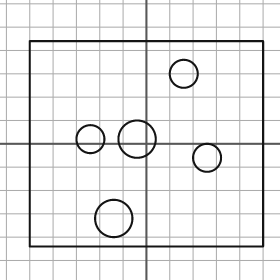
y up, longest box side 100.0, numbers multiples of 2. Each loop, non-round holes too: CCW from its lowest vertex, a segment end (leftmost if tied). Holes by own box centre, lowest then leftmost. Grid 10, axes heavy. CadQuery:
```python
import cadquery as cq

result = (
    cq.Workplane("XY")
    .moveTo(-50.0, -44.0)
    .lineTo(50.0, -44.0)
    .lineTo(50.0, 44.0)
    .lineTo(-50.0, 44.0)
    .close()
    .moveTo(-14.0, -32.0)
    .circle(8.0)
    .moveTo(26.0, -6.0)
    .circle(6.0)
    .moveTo(-24.0, 2.0)
    .circle(6.0)
    .moveTo(-4.0, 2.0)
    .circle(8.0)
    .moveTo(16.0, 30.0)
    .circle(6.0)
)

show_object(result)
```